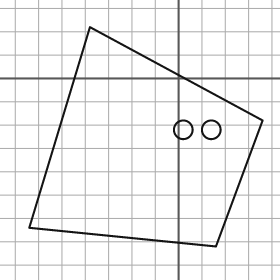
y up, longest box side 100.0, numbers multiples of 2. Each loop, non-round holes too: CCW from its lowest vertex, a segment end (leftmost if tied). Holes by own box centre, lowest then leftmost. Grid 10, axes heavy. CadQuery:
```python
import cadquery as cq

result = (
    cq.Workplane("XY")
    .moveTo(16.0, -72.0)
    .lineTo(36.0, -18.0)
    .lineTo(-38.0, 22.0)
    .lineTo(-64.0, -64.0)
    .close()
    .moveTo(2.0, -22.0)
    .circle(4.0)
    .moveTo(14.0, -22.0)
    .circle(4.0)
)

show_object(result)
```